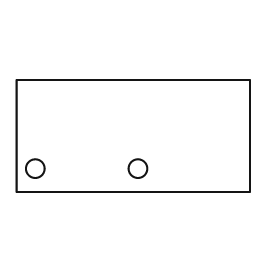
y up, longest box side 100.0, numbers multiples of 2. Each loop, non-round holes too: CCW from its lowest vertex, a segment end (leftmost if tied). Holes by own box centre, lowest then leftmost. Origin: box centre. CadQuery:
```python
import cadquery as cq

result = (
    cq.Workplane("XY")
    .moveTo(-50.0, -24.0)
    .lineTo(50.0, -24.0)
    .lineTo(50.0, 24.0)
    .lineTo(-50.0, 24.0)
    .close()
    .moveTo(-42.0, -14.0)
    .circle(4.0)
    .moveTo(2.0, -14.0)
    .circle(4.0)
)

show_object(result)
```